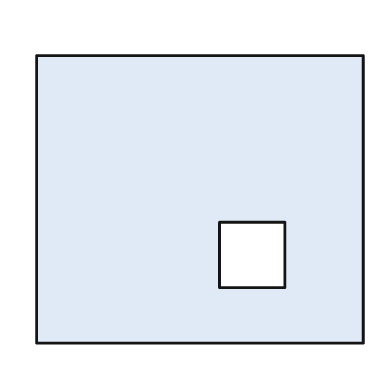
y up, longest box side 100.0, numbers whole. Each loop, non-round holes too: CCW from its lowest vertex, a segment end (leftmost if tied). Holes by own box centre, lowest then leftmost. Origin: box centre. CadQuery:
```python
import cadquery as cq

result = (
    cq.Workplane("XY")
    .moveTo(-50.0, -44.0)
    .lineTo(50.0, -44.0)
    .lineTo(50.0, 44.0)
    .lineTo(-50.0, 44.0)
    .close()
    .moveTo(6.0, -27.0)
    .lineTo(26.0, -27.0)
    .lineTo(26.0, -7.0)
    .lineTo(6.0, -7.0)
    .close()
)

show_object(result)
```